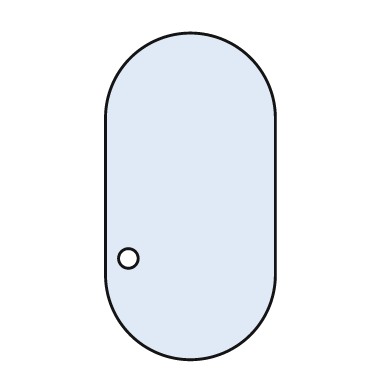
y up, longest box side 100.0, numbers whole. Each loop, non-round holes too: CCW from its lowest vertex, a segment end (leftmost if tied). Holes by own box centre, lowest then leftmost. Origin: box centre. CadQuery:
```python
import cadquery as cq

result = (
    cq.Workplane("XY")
    .moveTo(-26.0, -24.0)
    .threePointArc((0.0, -50.0), (26.0, -24.0))
    .lineTo(26.0, 24.0)
    .threePointArc((0.0, 50.0), (-26.0, 24.0))
    .close()
    .moveTo(-19.0, -19.0)
    .circle(3.0)
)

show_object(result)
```